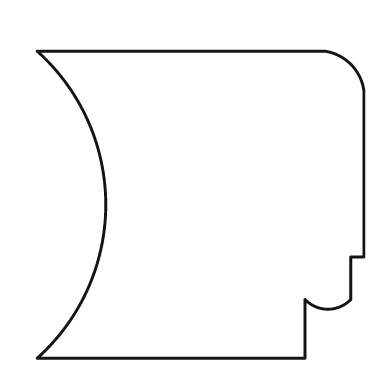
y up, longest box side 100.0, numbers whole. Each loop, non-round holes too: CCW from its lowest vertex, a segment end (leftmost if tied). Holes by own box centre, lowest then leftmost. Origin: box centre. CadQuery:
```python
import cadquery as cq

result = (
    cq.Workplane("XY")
    .moveTo(-50.0, -47.0)
    .lineTo(32.0, -47.0)
    .lineTo(32.0, -29.0)
    .threePointArc((39.0, -32.0), (46.0, -29.0))
    .lineTo(46.0, -16.0)
    .lineTo(50.0, -16.0)
    .lineTo(50.0, 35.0)
    .threePointArc((46.0, 43.0), (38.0, 47.0))
    .lineTo(-50.0, 47.0)
    .threePointArc((-29.0, 0.0), (-50.0, -47.0))
    .close()
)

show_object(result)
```